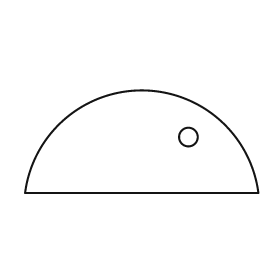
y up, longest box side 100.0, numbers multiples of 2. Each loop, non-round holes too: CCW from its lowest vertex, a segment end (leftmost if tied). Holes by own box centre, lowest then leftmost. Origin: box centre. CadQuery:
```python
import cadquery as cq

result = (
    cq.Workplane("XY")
    .moveTo(-50.0, -22.0)
    .lineTo(50.0, -22.0)
    .threePointArc((0.0, 22.0), (-50.0, -22.0))
    .close()
    .moveTo(20.0, 2.0)
    .circle(4.0)
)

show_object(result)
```